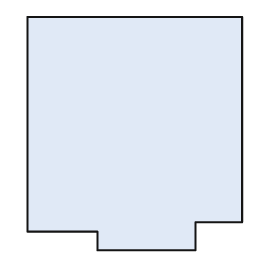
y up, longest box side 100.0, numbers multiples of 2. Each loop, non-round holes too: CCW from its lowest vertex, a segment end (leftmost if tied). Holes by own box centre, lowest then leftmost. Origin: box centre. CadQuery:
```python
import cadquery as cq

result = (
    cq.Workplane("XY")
    .moveTo(-16.0, -50.0)
    .lineTo(26.0, -50.0)
    .lineTo(26.0, -38.0)
    .lineTo(46.0, -38.0)
    .lineTo(46.0, 50.0)
    .lineTo(-46.0, 50.0)
    .lineTo(-46.0, -42.0)
    .lineTo(-16.0, -42.0)
    .close()
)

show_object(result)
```